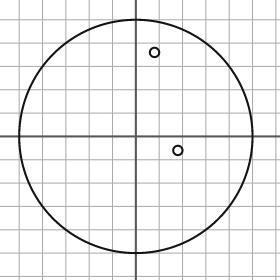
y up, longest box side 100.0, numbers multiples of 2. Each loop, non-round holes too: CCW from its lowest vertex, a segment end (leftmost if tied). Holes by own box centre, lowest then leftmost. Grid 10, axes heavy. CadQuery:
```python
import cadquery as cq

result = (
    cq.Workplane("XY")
    .moveTo(0.0, 0.0)
    .circle(50.0)
    .moveTo(18.0, -6.0)
    .circle(2.0)
    .moveTo(8.0, 36.0)
    .circle(2.0)
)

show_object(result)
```